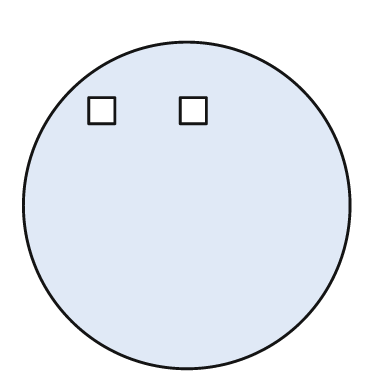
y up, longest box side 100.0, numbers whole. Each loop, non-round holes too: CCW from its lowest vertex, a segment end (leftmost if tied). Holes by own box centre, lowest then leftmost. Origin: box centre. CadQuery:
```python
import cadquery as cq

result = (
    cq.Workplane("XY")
    .moveTo(0.0, 0.0)
    .circle(50.0)
    .moveTo(-30.0, 25.0)
    .lineTo(-22.0, 25.0)
    .lineTo(-22.0, 33.0)
    .lineTo(-30.0, 33.0)
    .close()
    .moveTo(-2.0, 25.0)
    .lineTo(6.0, 25.0)
    .lineTo(6.0, 33.0)
    .lineTo(-2.0, 33.0)
    .close()
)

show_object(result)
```